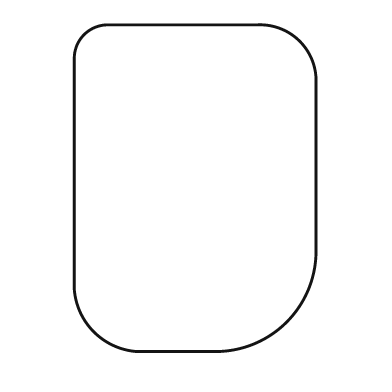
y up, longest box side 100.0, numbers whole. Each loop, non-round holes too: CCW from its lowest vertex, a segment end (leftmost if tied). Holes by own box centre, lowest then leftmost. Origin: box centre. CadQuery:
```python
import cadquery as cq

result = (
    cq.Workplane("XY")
    .moveTo(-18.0, -50.0)
    .lineTo(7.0, -50.0)
    .threePointArc((28.0, -41.0), (37.0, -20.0))
    .lineTo(37.0, 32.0)
    .threePointArc((32.0, 45.0), (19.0, 50.0))
    .lineTo(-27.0, 50.0)
    .threePointArc((-34.0, 47.0), (-37.0, 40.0))
    .lineTo(-37.0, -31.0)
    .threePointArc((-31.0, -44.0), (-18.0, -50.0))
    .close()
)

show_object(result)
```